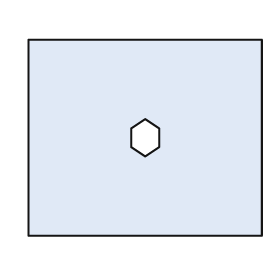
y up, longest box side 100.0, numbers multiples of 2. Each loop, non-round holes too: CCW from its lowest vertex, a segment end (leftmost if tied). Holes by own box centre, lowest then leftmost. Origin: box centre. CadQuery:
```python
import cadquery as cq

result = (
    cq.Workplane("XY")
    .moveTo(-50.0, -42.0)
    .lineTo(50.0, -42.0)
    .lineTo(50.0, 42.0)
    .lineTo(-50.0, 42.0)
    .close()
    .moveTo(0.0, -8.0)
    .lineTo(6.0, -4.0)
    .lineTo(6.0, 4.0)
    .lineTo(0.0, 8.0)
    .lineTo(-6.0, 4.0)
    .lineTo(-6.0, -4.0)
    .close()
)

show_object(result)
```